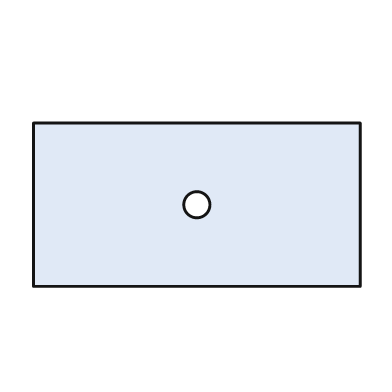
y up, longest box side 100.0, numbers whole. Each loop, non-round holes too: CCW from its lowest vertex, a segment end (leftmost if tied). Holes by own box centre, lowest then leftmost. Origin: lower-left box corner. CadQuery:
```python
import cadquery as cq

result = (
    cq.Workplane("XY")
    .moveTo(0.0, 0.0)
    .lineTo(100.0, 0.0)
    .lineTo(100.0, 50.0)
    .lineTo(0.0, 50.0)
    .close()
    .moveTo(50.0, 25.0)
    .circle(4.0)
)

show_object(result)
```